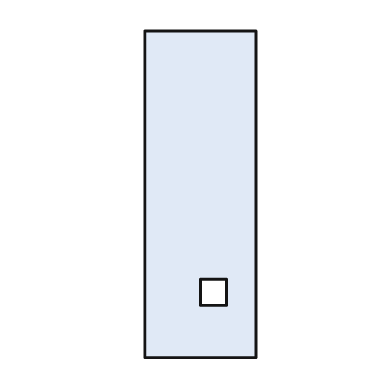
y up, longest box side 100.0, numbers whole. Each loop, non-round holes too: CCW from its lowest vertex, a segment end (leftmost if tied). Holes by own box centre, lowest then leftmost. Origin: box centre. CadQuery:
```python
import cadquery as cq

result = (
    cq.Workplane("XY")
    .moveTo(-17.0, -50.0)
    .lineTo(17.0, -50.0)
    .lineTo(17.0, 50.0)
    .lineTo(-17.0, 50.0)
    .close()
    .moveTo(0.0, -34.0)
    .lineTo(8.0, -34.0)
    .lineTo(8.0, -26.0)
    .lineTo(0.0, -26.0)
    .close()
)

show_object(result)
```